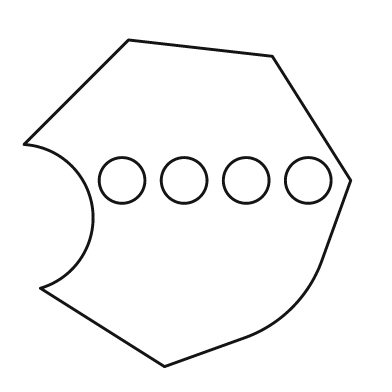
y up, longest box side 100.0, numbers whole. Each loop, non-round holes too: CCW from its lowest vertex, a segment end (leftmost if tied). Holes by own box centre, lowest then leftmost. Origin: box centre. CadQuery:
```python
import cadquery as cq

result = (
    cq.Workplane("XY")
    .moveTo(-7.0, -50.0)
    .lineTo(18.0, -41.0)
    .threePointArc((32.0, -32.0), (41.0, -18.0))
    .lineTo(50.0, 7.0)
    .lineTo(26.0, 45.0)
    .lineTo(-18.0, 50.0)
    .lineTo(-50.0, 18.0)
    .threePointArc((-29.0, -2.0), (-45.0, -26.0))
    .close()
    .moveTo(-20.0, 7.0)
    .circle(7.0)
    .moveTo(-1.0, 7.0)
    .circle(7.0)
    .moveTo(18.0, 7.0)
    .circle(7.0)
    .moveTo(37.0, 7.0)
    .circle(7.0)
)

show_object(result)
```